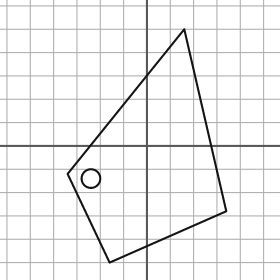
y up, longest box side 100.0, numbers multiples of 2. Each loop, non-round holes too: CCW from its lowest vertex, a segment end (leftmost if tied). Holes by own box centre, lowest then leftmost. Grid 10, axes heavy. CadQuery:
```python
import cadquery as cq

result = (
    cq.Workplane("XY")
    .moveTo(-16.0, -50.0)
    .lineTo(34.0, -28.0)
    .lineTo(16.0, 50.0)
    .lineTo(-34.0, -12.0)
    .close()
    .moveTo(-24.0, -14.0)
    .circle(4.0)
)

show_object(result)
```